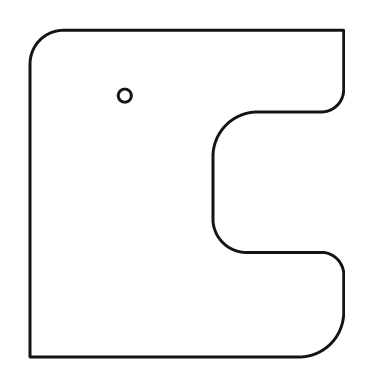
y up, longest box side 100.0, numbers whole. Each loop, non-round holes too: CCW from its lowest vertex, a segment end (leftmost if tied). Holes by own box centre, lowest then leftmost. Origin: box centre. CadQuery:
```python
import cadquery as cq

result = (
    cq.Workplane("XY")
    .moveTo(-48.0, -50.0)
    .lineTo(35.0, -50.0)
    .threePointArc((44.0, -46.0), (48.0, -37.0))
    .lineTo(48.0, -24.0)
    .threePointArc((46.0, -20.0), (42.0, -18.0))
    .lineTo(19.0, -18.0)
    .threePointArc((11.0, -15.0), (8.0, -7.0))
    .lineTo(8.0, 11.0)
    .threePointArc((12.0, 21.0), (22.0, 25.0))
    .lineTo(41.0, 25.0)
    .threePointArc((46.0, 27.0), (48.0, 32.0))
    .lineTo(48.0, 50.0)
    .lineTo(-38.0, 50.0)
    .threePointArc((-45.0, 47.0), (-48.0, 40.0))
    .close()
    .moveTo(-19.0, 30.0)
    .circle(2.0)
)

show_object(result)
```